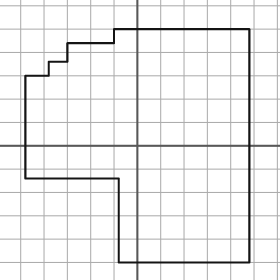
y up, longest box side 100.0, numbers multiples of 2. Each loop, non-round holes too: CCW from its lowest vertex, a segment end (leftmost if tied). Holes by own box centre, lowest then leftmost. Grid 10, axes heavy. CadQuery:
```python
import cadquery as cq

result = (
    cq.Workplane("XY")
    .moveTo(-8.0, -50.0)
    .lineTo(48.0, -50.0)
    .lineTo(48.0, 50.0)
    .lineTo(-10.0, 50.0)
    .lineTo(-10.0, 44.0)
    .lineTo(-30.0, 44.0)
    .lineTo(-30.0, 36.0)
    .lineTo(-38.0, 36.0)
    .lineTo(-38.0, 30.0)
    .lineTo(-48.0, 30.0)
    .lineTo(-48.0, -14.0)
    .lineTo(-8.0, -14.0)
    .close()
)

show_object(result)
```